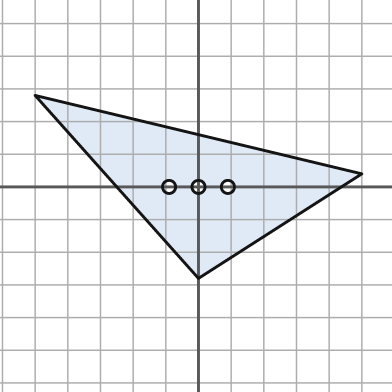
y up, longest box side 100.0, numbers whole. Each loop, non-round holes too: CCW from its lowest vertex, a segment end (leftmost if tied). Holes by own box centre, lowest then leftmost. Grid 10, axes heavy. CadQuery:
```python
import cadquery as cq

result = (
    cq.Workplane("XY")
    .moveTo(0.0, -28.0)
    .lineTo(50.0, 4.0)
    .lineTo(-50.0, 28.0)
    .close()
    .moveTo(-9.0, 0.0)
    .circle(2.0)
    .moveTo(0.0, 0.0)
    .circle(2.0)
    .moveTo(9.0, 0.0)
    .circle(2.0)
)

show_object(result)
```